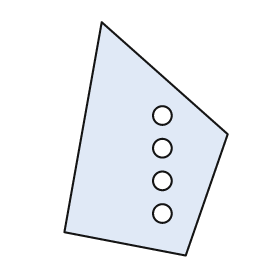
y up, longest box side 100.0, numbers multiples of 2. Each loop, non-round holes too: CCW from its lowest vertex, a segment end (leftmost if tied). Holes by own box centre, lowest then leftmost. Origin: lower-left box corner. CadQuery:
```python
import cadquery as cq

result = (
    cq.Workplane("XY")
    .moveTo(52.0, 0.0)
    .lineTo(70.0, 52.0)
    .lineTo(16.0, 100.0)
    .lineTo(0.0, 10.0)
    .close()
    .moveTo(42.0, 18.0)
    .circle(4.0)
    .moveTo(42.0, 32.0)
    .circle(4.0)
    .moveTo(42.0, 46.0)
    .circle(4.0)
    .moveTo(42.0, 60.0)
    .circle(4.0)
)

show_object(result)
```